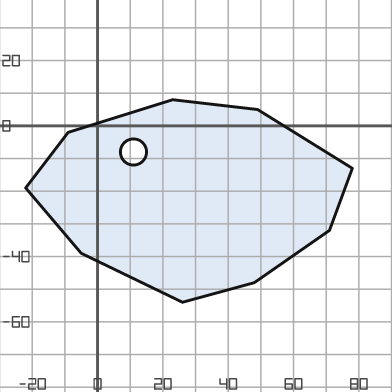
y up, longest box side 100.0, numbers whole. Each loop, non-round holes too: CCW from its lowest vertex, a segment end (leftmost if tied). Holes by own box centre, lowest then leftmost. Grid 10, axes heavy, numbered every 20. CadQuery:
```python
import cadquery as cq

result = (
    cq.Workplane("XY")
    .moveTo(26.0, -54.0)
    .lineTo(48.0, -48.0)
    .lineTo(71.0, -32.0)
    .lineTo(78.0, -13.0)
    .lineTo(49.0, 5.0)
    .lineTo(23.0, 8.0)
    .lineTo(-9.0, -2.0)
    .lineTo(-22.0, -19.0)
    .lineTo(-5.0, -39.0)
    .close()
    .moveTo(11.0, -8.0)
    .circle(4.0)
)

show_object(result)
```